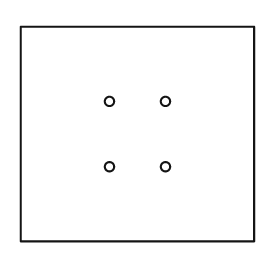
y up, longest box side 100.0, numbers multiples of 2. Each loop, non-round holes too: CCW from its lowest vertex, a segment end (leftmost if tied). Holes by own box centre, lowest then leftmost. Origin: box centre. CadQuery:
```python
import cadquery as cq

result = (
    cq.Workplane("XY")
    .moveTo(-50.0, -46.0)
    .lineTo(50.0, -46.0)
    .lineTo(50.0, 46.0)
    .lineTo(-50.0, 46.0)
    .close()
    .moveTo(-12.0, -14.0)
    .circle(2.0)
    .moveTo(12.0, -14.0)
    .circle(2.0)
    .moveTo(-12.0, 14.0)
    .circle(2.0)
    .moveTo(12.0, 14.0)
    .circle(2.0)
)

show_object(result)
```